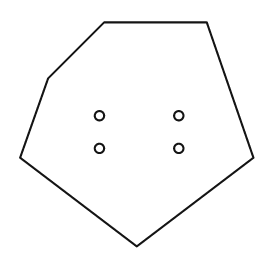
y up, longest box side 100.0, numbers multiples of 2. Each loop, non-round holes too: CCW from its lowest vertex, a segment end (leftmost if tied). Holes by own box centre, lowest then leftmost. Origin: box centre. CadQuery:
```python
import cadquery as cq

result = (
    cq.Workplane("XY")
    .moveTo(0.0, -48.0)
    .lineTo(50.0, -10.0)
    .lineTo(30.0, 48.0)
    .lineTo(-14.0, 48.0)
    .lineTo(-38.0, 24.0)
    .lineTo(-50.0, -10.0)
    .close()
    .moveTo(-16.0, -6.0)
    .circle(2.0)
    .moveTo(18.0, -6.0)
    .circle(2.0)
    .moveTo(-16.0, 8.0)
    .circle(2.0)
    .moveTo(18.0, 8.0)
    .circle(2.0)
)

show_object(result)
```